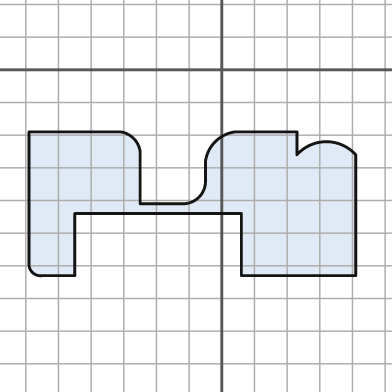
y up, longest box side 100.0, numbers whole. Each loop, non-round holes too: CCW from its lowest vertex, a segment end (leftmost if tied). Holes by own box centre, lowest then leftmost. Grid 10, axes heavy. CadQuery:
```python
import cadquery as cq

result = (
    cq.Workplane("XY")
    .moveTo(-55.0, -63.0)
    .lineTo(-45.0, -63.0)
    .lineTo(-45.0, -44.0)
    .lineTo(6.0, -44.0)
    .lineTo(6.0, -63.0)
    .lineTo(41.0, -63.0)
    .lineTo(41.0, -26.0)
    .threePointArc((32.0, -22.0), (23.0, -26.0))
    .lineTo(23.0, -19.0)
    .lineTo(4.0, -19.0)
    .threePointArc((-2.0, -22.0), (-5.0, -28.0))
    .lineTo(-5.0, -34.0)
    .threePointArc((-7.0, -39.0), (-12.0, -41.0))
    .lineTo(-25.0, -41.0)
    .lineTo(-25.0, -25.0)
    .threePointArc((-27.0, -21.0), (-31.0, -19.0))
    .lineTo(-59.0, -19.0)
    .lineTo(-59.0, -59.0)
    .threePointArc((-58.0, -62.0), (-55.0, -63.0))
    .close()
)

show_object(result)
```